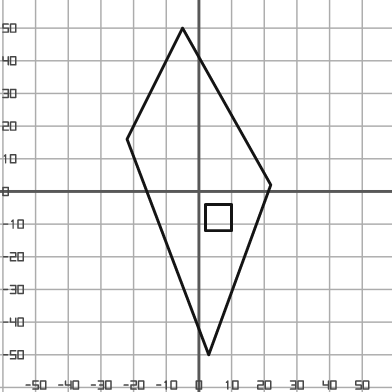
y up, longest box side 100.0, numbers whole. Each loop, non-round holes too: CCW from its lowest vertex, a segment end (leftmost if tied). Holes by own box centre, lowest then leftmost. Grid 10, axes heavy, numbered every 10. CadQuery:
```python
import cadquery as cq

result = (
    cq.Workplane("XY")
    .moveTo(3.0, -50.0)
    .lineTo(22.0, 2.0)
    .lineTo(-5.0, 50.0)
    .lineTo(-22.0, 16.0)
    .close()
    .moveTo(2.0, -12.0)
    .lineTo(10.0, -12.0)
    .lineTo(10.0, -4.0)
    .lineTo(2.0, -4.0)
    .close()
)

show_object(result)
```